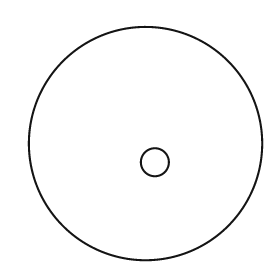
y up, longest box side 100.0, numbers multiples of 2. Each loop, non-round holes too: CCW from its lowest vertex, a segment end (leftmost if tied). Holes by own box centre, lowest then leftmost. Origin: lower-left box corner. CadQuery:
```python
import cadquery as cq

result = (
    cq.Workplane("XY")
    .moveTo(50.0, 50.0)
    .circle(50.0)
    .moveTo(54.0, 42.0)
    .circle(6.0)
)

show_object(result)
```